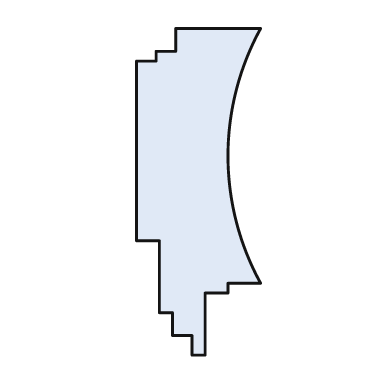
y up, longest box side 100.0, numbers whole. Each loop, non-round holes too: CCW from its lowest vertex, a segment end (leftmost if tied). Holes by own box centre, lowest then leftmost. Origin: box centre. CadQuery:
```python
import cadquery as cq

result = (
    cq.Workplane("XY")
    .moveTo(-2.0, -50.0)
    .lineTo(2.0, -50.0)
    .lineTo(2.0, -31.0)
    .lineTo(9.0, -31.0)
    .lineTo(9.0, -28.0)
    .lineTo(19.0, -28.0)
    .threePointArc((9.0, 11.0), (19.0, 50.0))
    .lineTo(-7.0, 50.0)
    .lineTo(-7.0, 43.0)
    .lineTo(-13.0, 43.0)
    .lineTo(-13.0, 40.0)
    .lineTo(-19.0, 40.0)
    .lineTo(-19.0, -15.0)
    .lineTo(-12.0, -15.0)
    .lineTo(-12.0, -37.0)
    .lineTo(-8.0, -37.0)
    .lineTo(-8.0, -44.0)
    .lineTo(-2.0, -44.0)
    .close()
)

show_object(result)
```